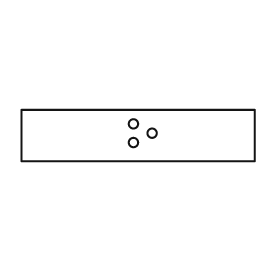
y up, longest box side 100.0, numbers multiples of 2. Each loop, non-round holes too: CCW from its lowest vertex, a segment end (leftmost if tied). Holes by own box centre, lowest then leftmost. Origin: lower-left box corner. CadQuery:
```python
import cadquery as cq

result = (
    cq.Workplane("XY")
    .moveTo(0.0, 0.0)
    .lineTo(100.0, 0.0)
    .lineTo(100.0, 22.0)
    .lineTo(0.0, 22.0)
    .close()
    .moveTo(48.0, 8.0)
    .circle(2.0)
    .moveTo(56.0, 12.0)
    .circle(2.0)
    .moveTo(48.0, 16.0)
    .circle(2.0)
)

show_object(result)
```